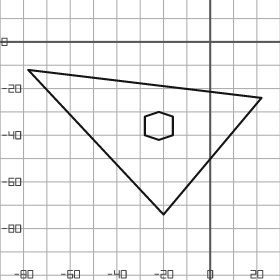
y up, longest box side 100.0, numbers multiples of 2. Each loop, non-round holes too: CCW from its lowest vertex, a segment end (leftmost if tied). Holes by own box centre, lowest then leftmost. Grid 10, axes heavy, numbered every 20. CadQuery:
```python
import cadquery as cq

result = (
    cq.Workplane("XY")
    .moveTo(-20.0, -74.0)
    .lineTo(22.0, -24.0)
    .lineTo(-78.0, -12.0)
    .close()
    .moveTo(-22.0, -42.0)
    .lineTo(-16.0, -40.0)
    .lineTo(-16.0, -32.0)
    .lineTo(-22.0, -30.0)
    .lineTo(-28.0, -32.0)
    .lineTo(-28.0, -40.0)
    .close()
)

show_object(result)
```